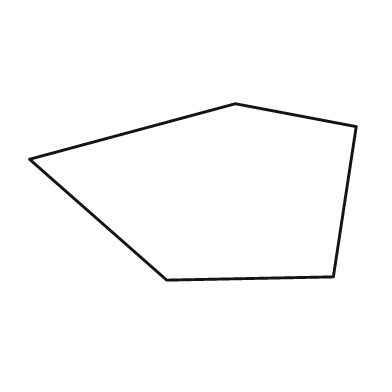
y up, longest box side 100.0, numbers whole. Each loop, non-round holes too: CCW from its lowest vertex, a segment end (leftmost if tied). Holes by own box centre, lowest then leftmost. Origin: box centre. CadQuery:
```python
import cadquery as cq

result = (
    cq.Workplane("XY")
    .moveTo(-8.0, -27.0)
    .lineTo(43.0, -26.0)
    .lineTo(50.0, 20.0)
    .lineTo(13.0, 27.0)
    .lineTo(-50.0, 10.0)
    .close()
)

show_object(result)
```